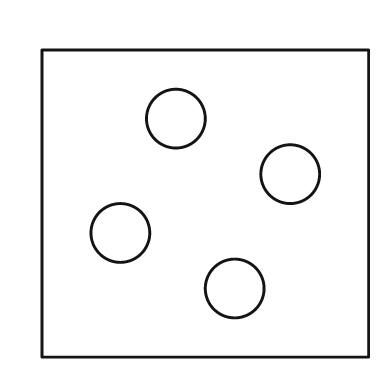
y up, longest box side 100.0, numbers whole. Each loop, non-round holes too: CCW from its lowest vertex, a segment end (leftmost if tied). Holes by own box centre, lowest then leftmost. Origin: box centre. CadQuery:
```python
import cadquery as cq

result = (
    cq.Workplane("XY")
    .moveTo(-50.0, -47.0)
    .lineTo(50.0, -47.0)
    .lineTo(50.0, 47.0)
    .lineTo(-50.0, 47.0)
    .close()
    .moveTo(9.0, -26.0)
    .circle(9.0)
    .moveTo(-26.0, -9.0)
    .circle(9.0)
    .moveTo(26.0, 9.0)
    .circle(9.0)
    .moveTo(-9.0, 26.0)
    .circle(9.0)
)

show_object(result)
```